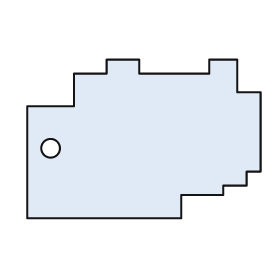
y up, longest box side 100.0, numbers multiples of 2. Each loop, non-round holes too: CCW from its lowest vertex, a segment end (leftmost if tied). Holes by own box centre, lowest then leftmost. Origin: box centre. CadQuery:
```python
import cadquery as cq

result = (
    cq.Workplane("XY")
    .moveTo(-50.0, -34.0)
    .lineTo(16.0, -34.0)
    .lineTo(16.0, -24.0)
    .lineTo(34.0, -24.0)
    .lineTo(34.0, -20.0)
    .lineTo(44.0, -20.0)
    .lineTo(44.0, -14.0)
    .lineTo(50.0, -14.0)
    .lineTo(50.0, 20.0)
    .lineTo(40.0, 20.0)
    .lineTo(40.0, 34.0)
    .lineTo(28.0, 34.0)
    .lineTo(28.0, 28.0)
    .lineTo(-2.0, 28.0)
    .lineTo(-2.0, 34.0)
    .lineTo(-16.0, 34.0)
    .lineTo(-16.0, 28.0)
    .lineTo(-30.0, 28.0)
    .lineTo(-30.0, 14.0)
    .lineTo(-50.0, 14.0)
    .close()
    .moveTo(-40.0, -4.0)
    .circle(4.0)
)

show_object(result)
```